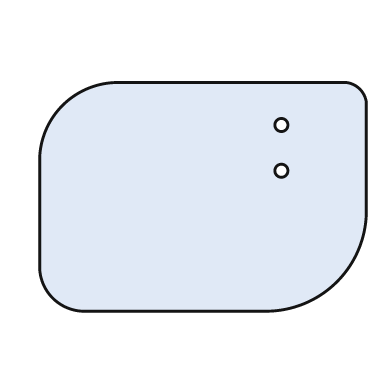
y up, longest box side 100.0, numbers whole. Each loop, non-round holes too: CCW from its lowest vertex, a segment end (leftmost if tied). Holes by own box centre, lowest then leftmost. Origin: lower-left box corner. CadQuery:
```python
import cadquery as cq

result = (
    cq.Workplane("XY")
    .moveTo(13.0, 0.0)
    .lineTo(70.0, 0.0)
    .threePointArc((91.0, 9.0), (100.0, 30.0))
    .lineTo(100.0, 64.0)
    .threePointArc((98.0, 68.0), (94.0, 70.0))
    .lineTo(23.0, 70.0)
    .threePointArc((7.0, 63.0), (0.0, 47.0))
    .lineTo(0.0, 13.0)
    .threePointArc((4.0, 4.0), (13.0, 0.0))
    .close()
    .moveTo(74.0, 43.0)
    .circle(2.0)
    .moveTo(74.0, 57.0)
    .circle(2.0)
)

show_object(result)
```